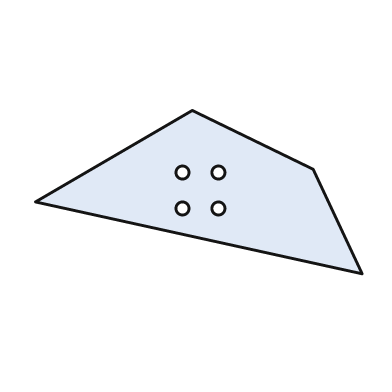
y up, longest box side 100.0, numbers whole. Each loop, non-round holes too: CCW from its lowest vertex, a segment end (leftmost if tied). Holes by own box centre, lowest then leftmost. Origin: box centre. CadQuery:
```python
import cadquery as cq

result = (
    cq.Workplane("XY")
    .moveTo(50.0, -25.0)
    .lineTo(35.0, 7.0)
    .lineTo(-2.0, 25.0)
    .lineTo(-50.0, -3.0)
    .close()
    .moveTo(-5.0, -5.0)
    .circle(2.0)
    .moveTo(6.0, -5.0)
    .circle(2.0)
    .moveTo(-5.0, 6.0)
    .circle(2.0)
    .moveTo(6.0, 6.0)
    .circle(2.0)
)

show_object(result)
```